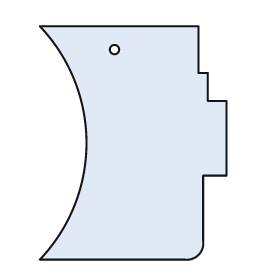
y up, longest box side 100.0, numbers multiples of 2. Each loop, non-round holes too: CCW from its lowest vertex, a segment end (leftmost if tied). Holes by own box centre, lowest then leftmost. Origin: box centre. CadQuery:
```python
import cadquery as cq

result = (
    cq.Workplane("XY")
    .moveTo(-40.0, -50.0)
    .lineTo(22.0, -50.0)
    .threePointArc((28.0, -48.0), (30.0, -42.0))
    .lineTo(30.0, -14.0)
    .lineTo(40.0, -14.0)
    .lineTo(40.0, 18.0)
    .lineTo(32.0, 18.0)
    .lineTo(32.0, 30.0)
    .lineTo(28.0, 30.0)
    .lineTo(28.0, 50.0)
    .lineTo(-40.0, 50.0)
    .threePointArc((-20.0, 0.0), (-40.0, -50.0))
    .close()
    .moveTo(-8.0, 40.0)
    .circle(2.0)
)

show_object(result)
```